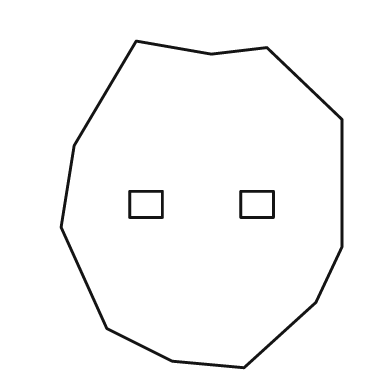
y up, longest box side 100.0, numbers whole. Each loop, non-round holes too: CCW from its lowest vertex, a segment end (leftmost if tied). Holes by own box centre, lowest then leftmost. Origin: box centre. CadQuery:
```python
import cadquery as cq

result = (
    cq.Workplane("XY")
    .moveTo(13.0, -50.0)
    .lineTo(35.0, -30.0)
    .lineTo(43.0, -13.0)
    .lineTo(43.0, 26.0)
    .lineTo(20.0, 48.0)
    .lineTo(3.0, 46.0)
    .lineTo(-20.0, 50.0)
    .lineTo(-39.0, 18.0)
    .lineTo(-43.0, -7.0)
    .lineTo(-29.0, -38.0)
    .lineTo(-9.0, -48.0)
    .close()
    .moveTo(-22.0, -4.0)
    .lineTo(-12.0, -4.0)
    .lineTo(-12.0, 4.0)
    .lineTo(-22.0, 4.0)
    .close()
    .moveTo(12.0, -4.0)
    .lineTo(22.0, -4.0)
    .lineTo(22.0, 4.0)
    .lineTo(12.0, 4.0)
    .close()
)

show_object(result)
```